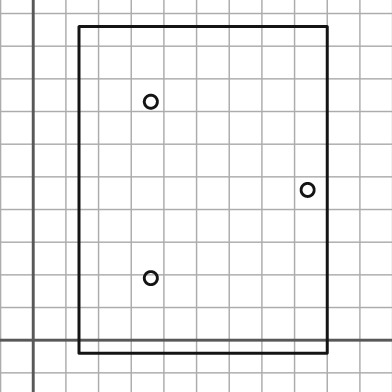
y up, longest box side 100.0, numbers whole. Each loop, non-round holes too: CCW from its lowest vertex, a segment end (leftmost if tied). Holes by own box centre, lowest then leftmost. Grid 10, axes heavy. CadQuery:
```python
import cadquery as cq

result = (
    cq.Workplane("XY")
    .moveTo(14.0, -4.0)
    .lineTo(90.0, -4.0)
    .lineTo(90.0, 96.0)
    .lineTo(14.0, 96.0)
    .close()
    .moveTo(36.0, 19.0)
    .circle(2.0)
    .moveTo(84.0, 46.0)
    .circle(2.0)
    .moveTo(36.0, 73.0)
    .circle(2.0)
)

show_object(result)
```